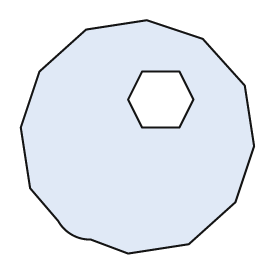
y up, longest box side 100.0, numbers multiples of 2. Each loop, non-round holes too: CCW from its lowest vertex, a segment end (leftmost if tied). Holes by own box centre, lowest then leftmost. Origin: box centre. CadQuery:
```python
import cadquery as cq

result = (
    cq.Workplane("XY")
    .moveTo(-4.0, -50.0)
    .lineTo(22.0, -46.0)
    .lineTo(42.0, -28.0)
    .lineTo(50.0, -4.0)
    .lineTo(46.0, 22.0)
    .lineTo(28.0, 42.0)
    .lineTo(4.0, 50.0)
    .lineTo(-22.0, 46.0)
    .lineTo(-42.0, 28.0)
    .lineTo(-50.0, 4.0)
    .lineTo(-46.0, -22.0)
    .lineTo(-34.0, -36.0)
    .threePointArc((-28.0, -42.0), (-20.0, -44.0))
    .close()
    .moveTo(2.0, 4.0)
    .lineTo(18.0, 4.0)
    .lineTo(24.0, 16.0)
    .lineTo(18.0, 28.0)
    .lineTo(2.0, 28.0)
    .lineTo(-4.0, 16.0)
    .close()
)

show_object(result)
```